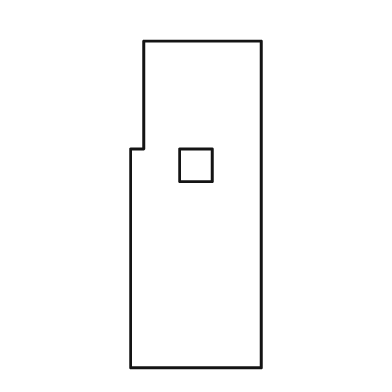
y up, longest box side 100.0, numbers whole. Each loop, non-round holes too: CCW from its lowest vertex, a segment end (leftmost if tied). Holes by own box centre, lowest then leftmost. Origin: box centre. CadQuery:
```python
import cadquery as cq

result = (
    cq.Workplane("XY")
    .moveTo(-20.0, -50.0)
    .lineTo(20.0, -50.0)
    .lineTo(20.0, 50.0)
    .lineTo(-16.0, 50.0)
    .lineTo(-16.0, 17.0)
    .lineTo(-20.0, 17.0)
    .close()
    .moveTo(-5.0, 7.0)
    .lineTo(5.0, 7.0)
    .lineTo(5.0, 17.0)
    .lineTo(-5.0, 17.0)
    .close()
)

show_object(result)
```